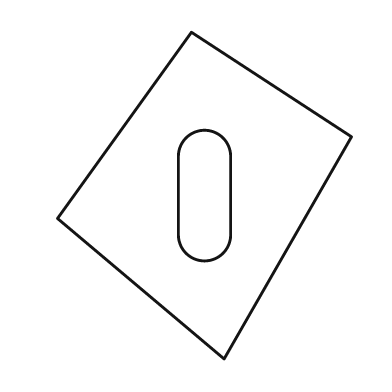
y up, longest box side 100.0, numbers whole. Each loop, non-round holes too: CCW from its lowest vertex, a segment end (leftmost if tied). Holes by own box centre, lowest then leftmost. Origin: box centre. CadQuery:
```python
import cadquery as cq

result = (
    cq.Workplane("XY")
    .moveTo(6.0, -50.0)
    .lineTo(45.0, 18.0)
    .lineTo(-4.0, 50.0)
    .lineTo(-45.0, -7.0)
    .close()
    .moveTo(-8.0, -12.0)
    .threePointArc((0.0, -20.0), (8.0, -12.0))
    .lineTo(8.0, 12.0)
    .threePointArc((0.0, 20.0), (-8.0, 12.0))
    .close()
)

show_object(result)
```